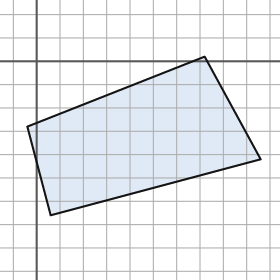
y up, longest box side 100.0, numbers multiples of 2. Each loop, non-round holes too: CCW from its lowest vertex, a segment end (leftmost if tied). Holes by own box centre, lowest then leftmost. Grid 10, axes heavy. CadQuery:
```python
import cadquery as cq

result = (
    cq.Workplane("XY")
    .moveTo(6.0, -66.0)
    .lineTo(96.0, -42.0)
    .lineTo(72.0, 2.0)
    .lineTo(-4.0, -28.0)
    .close()
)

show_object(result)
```